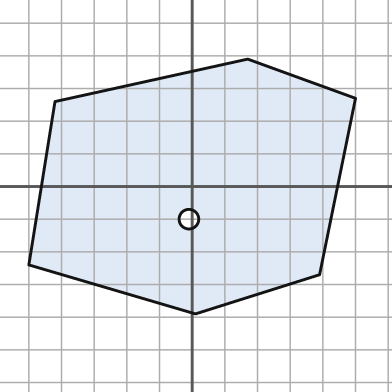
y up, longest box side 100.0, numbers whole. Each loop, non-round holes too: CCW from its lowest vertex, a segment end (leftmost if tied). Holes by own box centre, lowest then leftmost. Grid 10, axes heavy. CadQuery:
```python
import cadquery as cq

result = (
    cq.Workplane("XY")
    .moveTo(1.0, -39.0)
    .lineTo(39.0, -27.0)
    .lineTo(50.0, 27.0)
    .lineTo(17.0, 39.0)
    .lineTo(-42.0, 26.0)
    .lineTo(-50.0, -24.0)
    .close()
    .moveTo(-1.0, -10.0)
    .circle(3.0)
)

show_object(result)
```